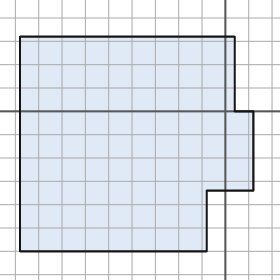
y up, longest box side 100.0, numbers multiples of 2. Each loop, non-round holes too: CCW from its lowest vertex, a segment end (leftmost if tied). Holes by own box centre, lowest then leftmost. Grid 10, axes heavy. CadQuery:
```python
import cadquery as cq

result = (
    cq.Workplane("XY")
    .moveTo(-88.0, -60.0)
    .lineTo(-8.0, -60.0)
    .lineTo(-8.0, -34.0)
    .lineTo(12.0, -34.0)
    .lineTo(12.0, 0.0)
    .lineTo(4.0, 0.0)
    .lineTo(4.0, 32.0)
    .lineTo(-88.0, 32.0)
    .close()
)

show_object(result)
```